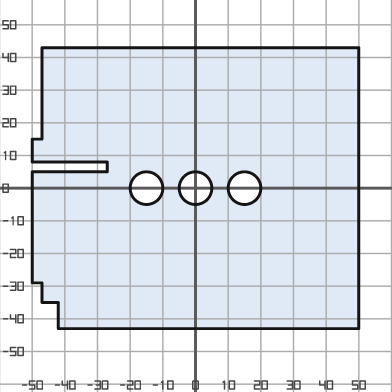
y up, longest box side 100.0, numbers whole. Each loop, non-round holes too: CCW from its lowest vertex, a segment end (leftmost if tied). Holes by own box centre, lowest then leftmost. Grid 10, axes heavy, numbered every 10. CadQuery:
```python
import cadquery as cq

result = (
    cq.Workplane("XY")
    .moveTo(-42.0, -43.0)
    .lineTo(50.0, -43.0)
    .lineTo(50.0, 43.0)
    .lineTo(-47.0, 43.0)
    .lineTo(-47.0, 15.0)
    .lineTo(-50.0, 15.0)
    .lineTo(-50.0, 8.0)
    .lineTo(-27.0, 8.0)
    .lineTo(-27.0, 5.0)
    .lineTo(-50.0, 5.0)
    .lineTo(-50.0, -29.0)
    .lineTo(-47.0, -29.0)
    .lineTo(-47.0, -35.0)
    .lineTo(-42.0, -35.0)
    .close()
    .moveTo(-15.0, 0.0)
    .circle(5.0)
    .moveTo(0.0, 0.0)
    .circle(5.0)
    .moveTo(15.0, 0.0)
    .circle(5.0)
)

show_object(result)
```